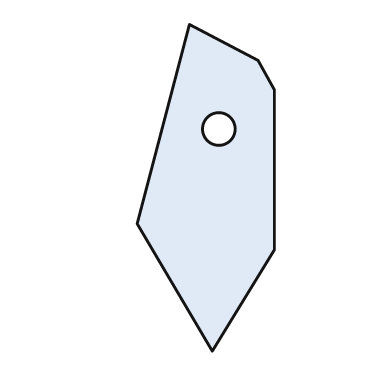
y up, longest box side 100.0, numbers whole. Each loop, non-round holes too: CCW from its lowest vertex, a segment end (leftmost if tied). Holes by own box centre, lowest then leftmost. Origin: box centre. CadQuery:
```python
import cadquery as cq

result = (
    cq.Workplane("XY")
    .moveTo(2.0, -50.0)
    .lineTo(21.0, -19.0)
    .lineTo(21.0, 30.0)
    .lineTo(16.0, 39.0)
    .lineTo(-5.0, 50.0)
    .lineTo(-21.0, -11.0)
    .close()
    .moveTo(4.0, 18.0)
    .circle(5.0)
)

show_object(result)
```